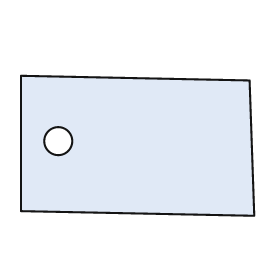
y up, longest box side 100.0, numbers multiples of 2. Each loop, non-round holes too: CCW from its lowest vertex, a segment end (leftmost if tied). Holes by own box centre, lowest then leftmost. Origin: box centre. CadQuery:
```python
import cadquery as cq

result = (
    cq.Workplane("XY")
    .moveTo(50.0, -30.0)
    .lineTo(48.0, 28.0)
    .lineTo(-50.0, 30.0)
    .lineTo(-50.0, -28.0)
    .close()
    .moveTo(-34.0, 2.0)
    .circle(6.0)
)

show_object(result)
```